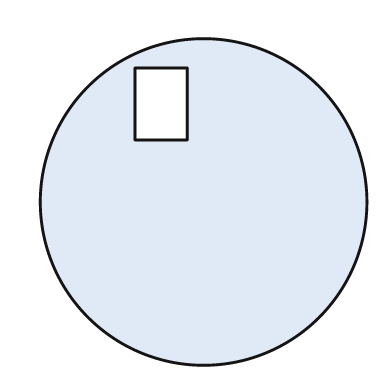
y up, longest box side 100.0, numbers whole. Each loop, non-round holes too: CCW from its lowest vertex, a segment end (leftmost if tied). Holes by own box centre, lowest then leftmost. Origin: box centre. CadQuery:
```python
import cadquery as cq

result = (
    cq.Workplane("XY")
    .moveTo(0.0, 0.0)
    .circle(50.0)
    .moveTo(-21.0, 19.0)
    .lineTo(-5.0, 19.0)
    .lineTo(-5.0, 41.0)
    .lineTo(-21.0, 41.0)
    .close()
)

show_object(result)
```